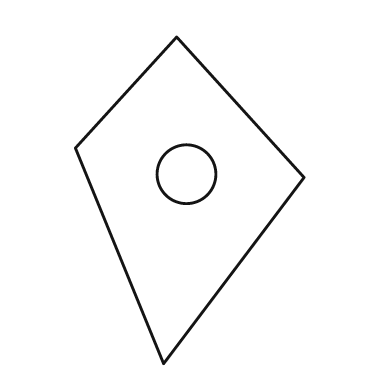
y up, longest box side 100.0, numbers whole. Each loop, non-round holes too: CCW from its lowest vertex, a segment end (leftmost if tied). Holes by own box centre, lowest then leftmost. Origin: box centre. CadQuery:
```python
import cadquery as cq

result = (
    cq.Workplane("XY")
    .moveTo(-8.0, -50.0)
    .lineTo(35.0, 7.0)
    .lineTo(-4.0, 50.0)
    .lineTo(-35.0, 16.0)
    .close()
    .moveTo(-1.0, 8.0)
    .circle(9.0)
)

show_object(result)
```